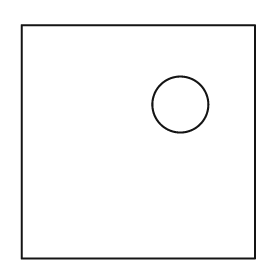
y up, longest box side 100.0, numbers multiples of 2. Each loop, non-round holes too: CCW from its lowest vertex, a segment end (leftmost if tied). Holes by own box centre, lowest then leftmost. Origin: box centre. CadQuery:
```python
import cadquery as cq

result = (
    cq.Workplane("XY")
    .moveTo(-50.0, -50.0)
    .lineTo(50.0, -50.0)
    .lineTo(50.0, 50.0)
    .lineTo(-50.0, 50.0)
    .close()
    .moveTo(18.0, 16.0)
    .circle(12.0)
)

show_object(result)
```